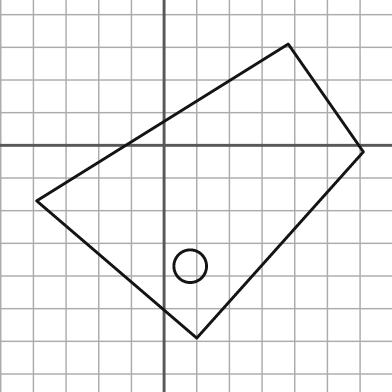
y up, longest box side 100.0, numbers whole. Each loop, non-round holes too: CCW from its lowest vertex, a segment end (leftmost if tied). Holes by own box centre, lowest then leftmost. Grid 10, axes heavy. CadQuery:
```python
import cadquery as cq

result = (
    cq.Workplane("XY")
    .moveTo(10.0, -59.0)
    .lineTo(61.0, -2.0)
    .lineTo(38.0, 31.0)
    .lineTo(-39.0, -17.0)
    .close()
    .moveTo(8.0, -37.0)
    .circle(5.0)
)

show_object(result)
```